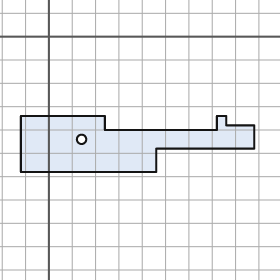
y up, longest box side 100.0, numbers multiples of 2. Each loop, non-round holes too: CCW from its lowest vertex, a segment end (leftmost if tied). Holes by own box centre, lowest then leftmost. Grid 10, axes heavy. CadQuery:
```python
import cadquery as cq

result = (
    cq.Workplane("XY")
    .moveTo(-12.0, -58.0)
    .lineTo(46.0, -58.0)
    .lineTo(46.0, -48.0)
    .lineTo(88.0, -48.0)
    .lineTo(88.0, -38.0)
    .lineTo(76.0, -38.0)
    .lineTo(76.0, -34.0)
    .lineTo(72.0, -34.0)
    .lineTo(72.0, -40.0)
    .lineTo(24.0, -40.0)
    .lineTo(24.0, -34.0)
    .lineTo(-12.0, -34.0)
    .close()
    .moveTo(14.0, -44.0)
    .circle(2.0)
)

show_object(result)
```